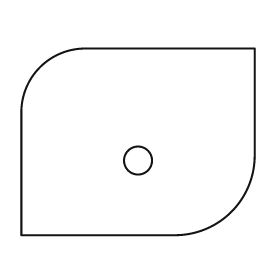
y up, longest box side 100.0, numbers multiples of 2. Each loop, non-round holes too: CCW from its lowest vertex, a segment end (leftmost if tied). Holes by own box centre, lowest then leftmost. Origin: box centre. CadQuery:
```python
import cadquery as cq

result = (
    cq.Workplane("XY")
    .moveTo(-50.0, -40.0)
    .lineTo(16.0, -40.0)
    .threePointArc((40.0, -30.0), (50.0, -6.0))
    .lineTo(50.0, 40.0)
    .lineTo(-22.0, 40.0)
    .threePointArc((-42.0, 32.0), (-50.0, 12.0))
    .close()
    .moveTo(0.0, -8.0)
    .circle(6.0)
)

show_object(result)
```